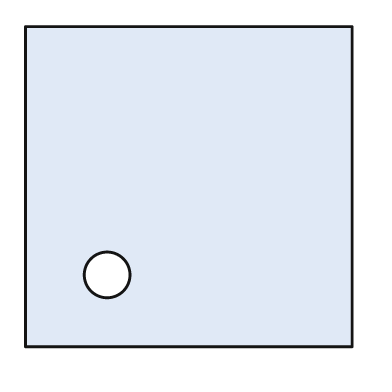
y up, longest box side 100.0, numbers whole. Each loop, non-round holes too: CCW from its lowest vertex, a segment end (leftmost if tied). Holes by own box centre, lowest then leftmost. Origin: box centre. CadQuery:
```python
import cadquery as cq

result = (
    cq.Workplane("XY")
    .moveTo(-50.0, -49.0)
    .lineTo(50.0, -49.0)
    .lineTo(50.0, 49.0)
    .lineTo(-50.0, 49.0)
    .close()
    .moveTo(-25.0, -27.0)
    .circle(7.0)
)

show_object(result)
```